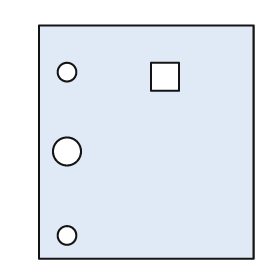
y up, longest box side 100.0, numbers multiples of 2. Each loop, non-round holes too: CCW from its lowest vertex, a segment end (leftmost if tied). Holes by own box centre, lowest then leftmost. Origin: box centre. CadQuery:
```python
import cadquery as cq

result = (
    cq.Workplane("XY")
    .moveTo(-46.0, -50.0)
    .lineTo(46.0, -50.0)
    .lineTo(46.0, 50.0)
    .lineTo(-46.0, 50.0)
    .close()
    .moveTo(-34.0, -40.0)
    .circle(4.0)
    .moveTo(-34.0, -4.0)
    .circle(6.0)
    .moveTo(2.0, 22.0)
    .lineTo(14.0, 22.0)
    .lineTo(14.0, 34.0)
    .lineTo(2.0, 34.0)
    .close()
    .moveTo(-34.0, 30.0)
    .circle(4.0)
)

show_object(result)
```